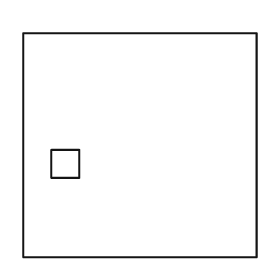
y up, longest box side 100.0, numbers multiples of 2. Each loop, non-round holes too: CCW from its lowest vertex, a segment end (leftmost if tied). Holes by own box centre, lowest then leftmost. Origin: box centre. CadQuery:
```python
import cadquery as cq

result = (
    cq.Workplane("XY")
    .moveTo(-50.0, -48.0)
    .lineTo(50.0, -48.0)
    .lineTo(50.0, 48.0)
    .lineTo(-50.0, 48.0)
    .close()
    .moveTo(-38.0, -14.0)
    .lineTo(-26.0, -14.0)
    .lineTo(-26.0, -2.0)
    .lineTo(-38.0, -2.0)
    .close()
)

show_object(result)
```